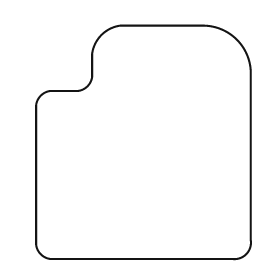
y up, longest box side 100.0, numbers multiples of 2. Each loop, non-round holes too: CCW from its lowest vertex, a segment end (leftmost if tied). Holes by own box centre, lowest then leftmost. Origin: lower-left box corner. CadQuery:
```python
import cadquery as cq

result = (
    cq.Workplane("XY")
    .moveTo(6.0, 0.0)
    .lineTo(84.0, 0.0)
    .threePointArc((90.0, 2.0), (92.0, 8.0))
    .lineTo(92.0, 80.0)
    .threePointArc((86.0, 94.0), (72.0, 100.0))
    .lineTo(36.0, 100.0)
    .threePointArc((28.0, 96.0), (24.0, 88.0))
    .lineTo(24.0, 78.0)
    .threePointArc((22.0, 74.0), (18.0, 72.0))
    .lineTo(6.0, 72.0)
    .threePointArc((2.0, 70.0), (0.0, 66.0))
    .lineTo(0.0, 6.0)
    .threePointArc((2.0, 2.0), (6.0, 0.0))
    .close()
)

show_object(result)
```